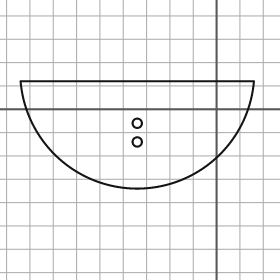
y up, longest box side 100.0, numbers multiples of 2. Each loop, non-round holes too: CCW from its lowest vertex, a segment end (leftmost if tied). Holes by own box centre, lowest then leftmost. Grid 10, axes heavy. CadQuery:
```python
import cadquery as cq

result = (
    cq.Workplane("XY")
    .moveTo(-84.0, 12.0)
    .threePointArc((-34.0, -34.0), (16.0, 12.0))
    .close()
    .moveTo(-34.0, -14.0)
    .circle(2.0)
    .moveTo(-34.0, -6.0)
    .circle(2.0)
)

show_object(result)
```